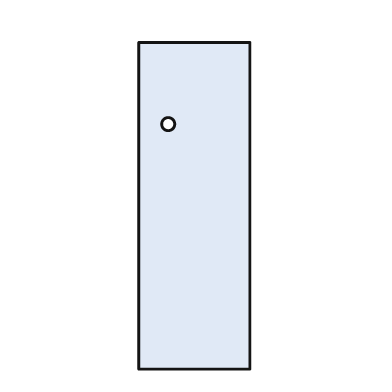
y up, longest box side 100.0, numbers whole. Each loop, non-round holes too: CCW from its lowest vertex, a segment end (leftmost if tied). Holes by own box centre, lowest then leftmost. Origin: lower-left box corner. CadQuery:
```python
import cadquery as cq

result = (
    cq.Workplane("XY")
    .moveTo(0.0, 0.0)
    .lineTo(34.0, 0.0)
    .lineTo(34.0, 100.0)
    .lineTo(0.0, 100.0)
    .close()
    .moveTo(9.0, 75.0)
    .circle(2.0)
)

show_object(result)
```